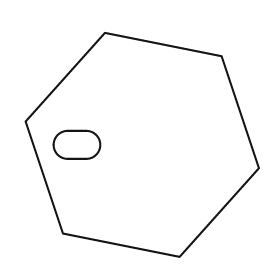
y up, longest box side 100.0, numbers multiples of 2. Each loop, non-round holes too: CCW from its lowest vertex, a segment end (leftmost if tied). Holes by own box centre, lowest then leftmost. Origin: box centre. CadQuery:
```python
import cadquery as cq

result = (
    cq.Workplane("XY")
    .moveTo(16.0, -48.0)
    .lineTo(50.0, -10.0)
    .lineTo(34.0, 38.0)
    .lineTo(-16.0, 48.0)
    .lineTo(-50.0, 10.0)
    .lineTo(-34.0, -38.0)
    .close()
    .moveTo(-32.0, -6.0)
    .lineTo(-24.0, -6.0)
    .threePointArc((-18.0, 0.0), (-24.0, 6.0))
    .lineTo(-32.0, 6.0)
    .threePointArc((-38.0, 0.0), (-32.0, -6.0))
    .close()
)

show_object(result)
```